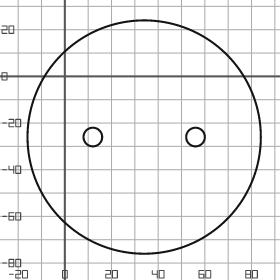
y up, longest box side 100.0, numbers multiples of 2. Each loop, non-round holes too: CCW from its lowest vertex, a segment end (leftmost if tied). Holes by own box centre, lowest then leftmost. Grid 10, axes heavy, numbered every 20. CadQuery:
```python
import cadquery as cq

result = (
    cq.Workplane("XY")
    .moveTo(34.0, -26.0)
    .circle(50.0)
    .moveTo(12.0, -26.0)
    .circle(4.0)
    .moveTo(56.0, -26.0)
    .circle(4.0)
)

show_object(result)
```